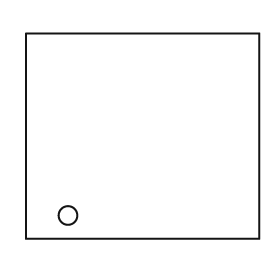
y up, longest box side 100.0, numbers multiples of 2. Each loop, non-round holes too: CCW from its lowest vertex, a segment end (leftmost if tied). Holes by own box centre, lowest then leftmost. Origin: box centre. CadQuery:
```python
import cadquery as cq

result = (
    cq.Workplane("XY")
    .moveTo(-50.0, -44.0)
    .lineTo(50.0, -44.0)
    .lineTo(50.0, 44.0)
    .lineTo(-50.0, 44.0)
    .close()
    .moveTo(-32.0, -34.0)
    .circle(4.0)
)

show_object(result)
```